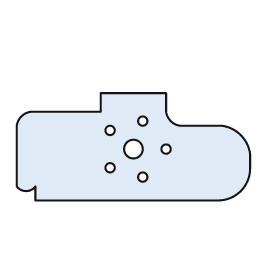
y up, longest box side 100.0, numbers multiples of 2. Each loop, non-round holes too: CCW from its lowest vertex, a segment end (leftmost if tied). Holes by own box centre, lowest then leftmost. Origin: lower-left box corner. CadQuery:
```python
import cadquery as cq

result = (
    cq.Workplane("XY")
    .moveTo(8.0, 0.0)
    .lineTo(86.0, 0.0)
    .threePointArc((96.0, 4.0), (100.0, 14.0))
    .lineTo(100.0, 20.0)
    .threePointArc((96.0, 28.0), (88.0, 32.0))
    .lineTo(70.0, 32.0)
    .threePointArc((66.0, 34.0), (64.0, 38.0))
    .lineTo(64.0, 46.0)
    .lineTo(36.0, 46.0)
    .lineTo(36.0, 38.0)
    .lineTo(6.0, 38.0)
    .threePointArc((2.0, 36.0), (0.0, 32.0))
    .lineTo(0.0, 6.0)
    .threePointArc((4.0, 4.0), (8.0, 6.0))
    .close()
    .moveTo(54.0, 10.0)
    .circle(2.0)
    .moveTo(40.0, 14.0)
    .circle(2.0)
    .moveTo(50.0, 22.0)
    .circle(4.0)
    .moveTo(64.0, 22.0)
    .circle(2.0)
    .moveTo(40.0, 30.0)
    .circle(2.0)
    .moveTo(54.0, 34.0)
    .circle(2.0)
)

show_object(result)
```